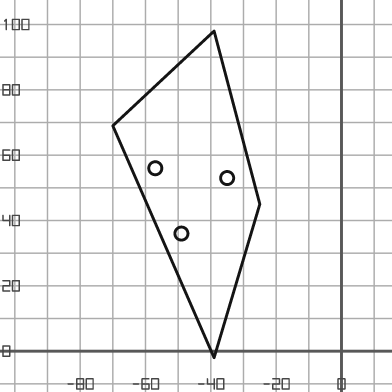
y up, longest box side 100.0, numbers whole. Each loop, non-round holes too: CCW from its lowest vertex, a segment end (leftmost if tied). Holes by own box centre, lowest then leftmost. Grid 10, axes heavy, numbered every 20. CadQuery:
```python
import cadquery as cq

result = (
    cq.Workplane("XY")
    .moveTo(-39.0, -2.0)
    .lineTo(-25.0, 45.0)
    .lineTo(-39.0, 98.0)
    .lineTo(-70.0, 69.0)
    .close()
    .moveTo(-49.0, 36.0)
    .circle(2.0)
    .moveTo(-35.0, 53.0)
    .circle(2.0)
    .moveTo(-57.0, 56.0)
    .circle(2.0)
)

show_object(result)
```